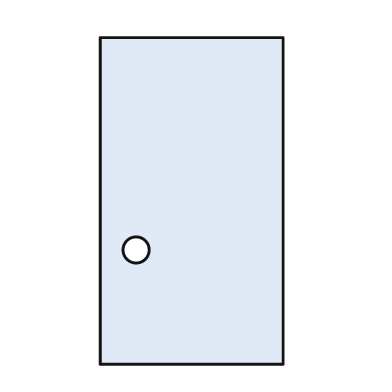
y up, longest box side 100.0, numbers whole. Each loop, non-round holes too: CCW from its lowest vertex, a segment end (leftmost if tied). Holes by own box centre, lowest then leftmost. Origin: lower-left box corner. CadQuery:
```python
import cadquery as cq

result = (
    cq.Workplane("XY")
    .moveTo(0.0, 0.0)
    .lineTo(56.0, 0.0)
    .lineTo(56.0, 100.0)
    .lineTo(0.0, 100.0)
    .close()
    .moveTo(11.0, 35.0)
    .circle(4.0)
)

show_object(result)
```